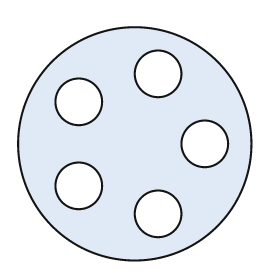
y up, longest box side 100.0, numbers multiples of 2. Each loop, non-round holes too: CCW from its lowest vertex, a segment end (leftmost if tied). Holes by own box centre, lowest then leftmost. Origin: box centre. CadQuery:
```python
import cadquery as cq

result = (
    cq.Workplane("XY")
    .moveTo(0.0, 0.0)
    .circle(50.0)
    .moveTo(10.0, -30.0)
    .circle(10.0)
    .moveTo(-24.0, -18.0)
    .circle(10.0)
    .moveTo(30.0, 0.0)
    .circle(10.0)
    .moveTo(-24.0, 18.0)
    .circle(10.0)
    .moveTo(10.0, 30.0)
    .circle(10.0)
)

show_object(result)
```